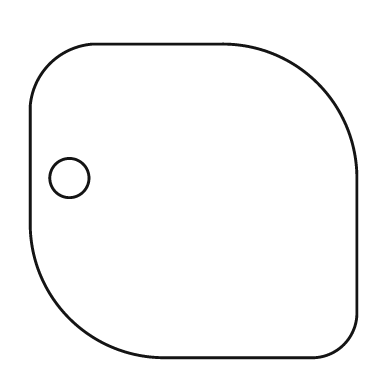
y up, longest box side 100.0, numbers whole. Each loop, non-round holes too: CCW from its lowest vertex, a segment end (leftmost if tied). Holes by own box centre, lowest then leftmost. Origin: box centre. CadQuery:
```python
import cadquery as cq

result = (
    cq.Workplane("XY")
    .moveTo(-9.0, -48.0)
    .lineTo(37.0, -48.0)
    .threePointArc((46.0, -44.0), (50.0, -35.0))
    .lineTo(50.0, 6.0)
    .threePointArc((38.0, 36.0), (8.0, 48.0))
    .lineTo(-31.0, 48.0)
    .threePointArc((-44.0, 42.0), (-50.0, 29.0))
    .lineTo(-50.0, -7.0)
    .threePointArc((-38.0, -36.0), (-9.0, -48.0))
    .close()
    .moveTo(-38.0, 7.0)
    .circle(6.0)
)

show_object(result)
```